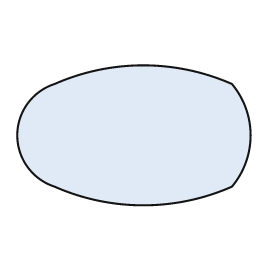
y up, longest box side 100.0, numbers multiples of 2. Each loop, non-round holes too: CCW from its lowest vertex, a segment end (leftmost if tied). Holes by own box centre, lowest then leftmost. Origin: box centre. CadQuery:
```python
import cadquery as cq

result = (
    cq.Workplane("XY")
    .moveTo(-34.0, -22.0)
    .threePointArc((4.0, -30.0), (42.0, -22.0))
    .threePointArc((50.0, 0.0), (42.0, 22.0))
    .threePointArc((4.0, 30.0), (-34.0, 22.0))
    .threePointArc((-50.0, 0.0), (-34.0, -22.0))
    .close()
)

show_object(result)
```